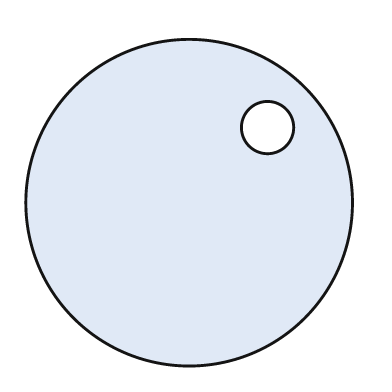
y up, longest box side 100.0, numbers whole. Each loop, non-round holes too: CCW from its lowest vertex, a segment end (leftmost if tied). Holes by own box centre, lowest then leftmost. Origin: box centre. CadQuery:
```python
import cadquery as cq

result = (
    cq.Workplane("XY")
    .moveTo(0.0, 0.0)
    .circle(50.0)
    .moveTo(24.0, 23.0)
    .circle(8.0)
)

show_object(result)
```